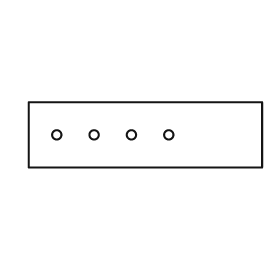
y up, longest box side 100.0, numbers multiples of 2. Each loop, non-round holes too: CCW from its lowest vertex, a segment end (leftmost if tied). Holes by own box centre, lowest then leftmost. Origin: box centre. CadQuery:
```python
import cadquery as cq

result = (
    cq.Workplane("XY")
    .moveTo(-50.0, -14.0)
    .lineTo(50.0, -14.0)
    .lineTo(50.0, 14.0)
    .lineTo(-50.0, 14.0)
    .close()
    .moveTo(-38.0, 0.0)
    .circle(2.0)
    .moveTo(-22.0, 0.0)
    .circle(2.0)
    .moveTo(-6.0, 0.0)
    .circle(2.0)
    .moveTo(10.0, 0.0)
    .circle(2.0)
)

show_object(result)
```